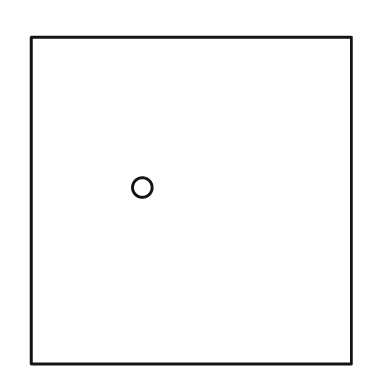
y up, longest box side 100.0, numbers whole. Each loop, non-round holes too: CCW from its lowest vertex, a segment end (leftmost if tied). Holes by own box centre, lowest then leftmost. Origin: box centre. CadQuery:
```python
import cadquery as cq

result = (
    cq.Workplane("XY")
    .moveTo(-49.0, -50.0)
    .lineTo(49.0, -50.0)
    .lineTo(49.0, 50.0)
    .lineTo(-49.0, 50.0)
    .close()
    .moveTo(-15.0, 4.0)
    .circle(3.0)
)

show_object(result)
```